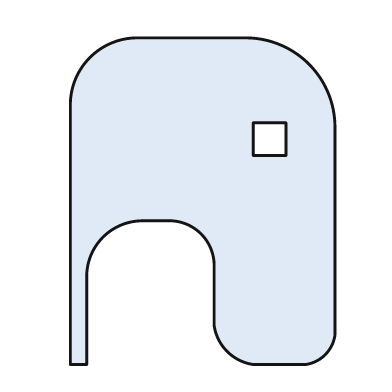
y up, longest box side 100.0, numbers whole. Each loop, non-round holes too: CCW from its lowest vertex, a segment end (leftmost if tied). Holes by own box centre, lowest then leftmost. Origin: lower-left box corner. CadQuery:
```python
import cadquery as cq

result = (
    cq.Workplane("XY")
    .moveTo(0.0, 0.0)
    .lineTo(5.0, 0.0)
    .lineTo(5.0, 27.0)
    .threePointArc((10.0, 39.0), (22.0, 44.0))
    .lineTo(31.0, 44.0)
    .threePointArc((40.0, 40.0), (44.0, 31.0))
    .lineTo(44.0, 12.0)
    .threePointArc((48.0, 4.0), (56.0, 0.0))
    .lineTo(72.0, 0.0)
    .threePointArc((78.0, 3.0), (81.0, 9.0))
    .lineTo(81.0, 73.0)
    .threePointArc((73.0, 92.0), (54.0, 100.0))
    .lineTo(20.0, 100.0)
    .threePointArc((6.0, 94.0), (0.0, 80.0))
    .close()
    .moveTo(56.0, 64.0)
    .lineTo(66.0, 64.0)
    .lineTo(66.0, 74.0)
    .lineTo(56.0, 74.0)
    .close()
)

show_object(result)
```